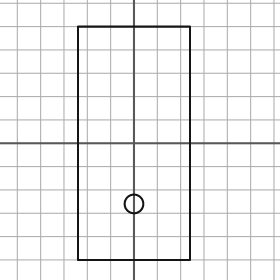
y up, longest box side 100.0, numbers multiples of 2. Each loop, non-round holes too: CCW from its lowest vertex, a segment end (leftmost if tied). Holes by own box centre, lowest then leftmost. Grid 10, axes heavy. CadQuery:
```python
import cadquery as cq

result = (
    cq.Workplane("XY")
    .moveTo(-24.0, -50.0)
    .lineTo(24.0, -50.0)
    .lineTo(24.0, 50.0)
    .lineTo(-24.0, 50.0)
    .close()
    .moveTo(0.0, -26.0)
    .circle(4.0)
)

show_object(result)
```